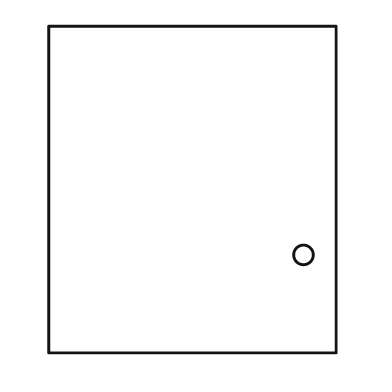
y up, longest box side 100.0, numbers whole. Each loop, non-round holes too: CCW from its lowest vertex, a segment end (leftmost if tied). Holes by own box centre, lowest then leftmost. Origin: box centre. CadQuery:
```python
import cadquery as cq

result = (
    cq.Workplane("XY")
    .moveTo(-44.0, -50.0)
    .lineTo(44.0, -50.0)
    .lineTo(44.0, 50.0)
    .lineTo(-44.0, 50.0)
    .close()
    .moveTo(34.0, -20.0)
    .circle(3.0)
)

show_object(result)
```